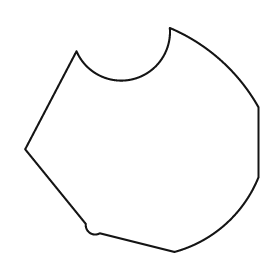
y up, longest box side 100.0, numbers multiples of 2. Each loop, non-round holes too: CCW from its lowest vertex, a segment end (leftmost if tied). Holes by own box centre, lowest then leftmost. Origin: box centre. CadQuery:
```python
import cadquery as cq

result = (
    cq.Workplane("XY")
    .moveTo(14.0, -48.0)
    .threePointArc((36.0, -36.0), (50.0, -16.0))
    .lineTo(50.0, 14.0)
    .threePointArc((34.0, 34.0), (12.0, 48.0))
    .threePointArc((-4.0, 26.0), (-28.0, 38.0))
    .lineTo(-50.0, -4.0)
    .lineTo(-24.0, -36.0)
    .threePointArc((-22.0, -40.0), (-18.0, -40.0))
    .close()
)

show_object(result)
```